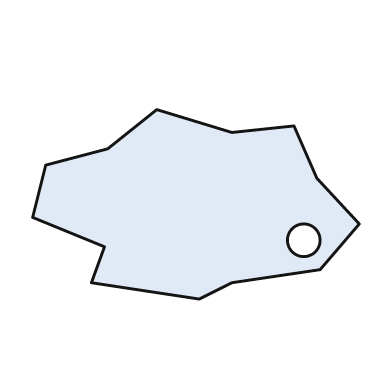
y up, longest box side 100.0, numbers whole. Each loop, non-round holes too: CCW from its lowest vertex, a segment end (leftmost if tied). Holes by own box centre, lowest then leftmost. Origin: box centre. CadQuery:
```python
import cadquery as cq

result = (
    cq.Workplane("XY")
    .moveTo(1.0, -29.0)
    .lineTo(11.0, -24.0)
    .lineTo(38.0, -20.0)
    .lineTo(50.0, -6.0)
    .lineTo(37.0, 8.0)
    .lineTo(30.0, 24.0)
    .lineTo(11.0, 22.0)
    .lineTo(-12.0, 29.0)
    .lineTo(-27.0, 17.0)
    .lineTo(-46.0, 12.0)
    .lineTo(-50.0, -4.0)
    .lineTo(-28.0, -13.0)
    .lineTo(-32.0, -24.0)
    .close()
    .moveTo(33.0, -11.0)
    .circle(5.0)
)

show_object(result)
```